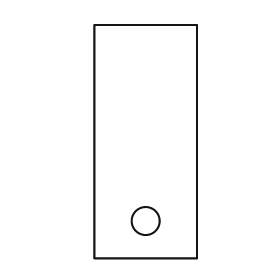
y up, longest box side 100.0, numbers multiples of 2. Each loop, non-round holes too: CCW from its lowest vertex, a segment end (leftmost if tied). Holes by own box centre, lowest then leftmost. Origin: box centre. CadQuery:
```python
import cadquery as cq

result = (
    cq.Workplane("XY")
    .moveTo(-22.0, -50.0)
    .lineTo(22.0, -50.0)
    .lineTo(22.0, 50.0)
    .lineTo(-22.0, 50.0)
    .close()
    .moveTo(0.0, -34.0)
    .circle(6.0)
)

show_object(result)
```